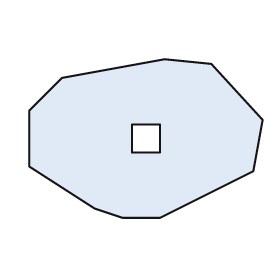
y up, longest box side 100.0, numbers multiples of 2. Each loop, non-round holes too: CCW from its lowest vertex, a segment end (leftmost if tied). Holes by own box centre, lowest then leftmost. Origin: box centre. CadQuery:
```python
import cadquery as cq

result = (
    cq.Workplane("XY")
    .moveTo(-10.0, -34.0)
    .lineTo(6.0, -34.0)
    .lineTo(46.0, -14.0)
    .lineTo(50.0, 8.0)
    .lineTo(28.0, 32.0)
    .lineTo(8.0, 34.0)
    .lineTo(-36.0, 26.0)
    .lineTo(-50.0, 12.0)
    .lineTo(-50.0, -12.0)
    .lineTo(-22.0, -30.0)
    .close()
    .moveTo(-6.0, -6.0)
    .lineTo(6.0, -6.0)
    .lineTo(6.0, 6.0)
    .lineTo(-6.0, 6.0)
    .close()
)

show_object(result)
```